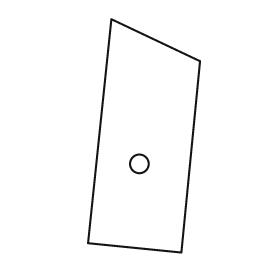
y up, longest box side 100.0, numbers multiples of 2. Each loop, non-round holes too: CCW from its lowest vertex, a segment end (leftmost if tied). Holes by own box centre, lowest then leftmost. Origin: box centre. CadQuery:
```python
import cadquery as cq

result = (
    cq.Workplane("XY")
    .moveTo(16.0, -50.0)
    .lineTo(24.0, 32.0)
    .lineTo(-14.0, 50.0)
    .lineTo(-24.0, -46.0)
    .close()
    .moveTo(-2.0, -12.0)
    .circle(4.0)
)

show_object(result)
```